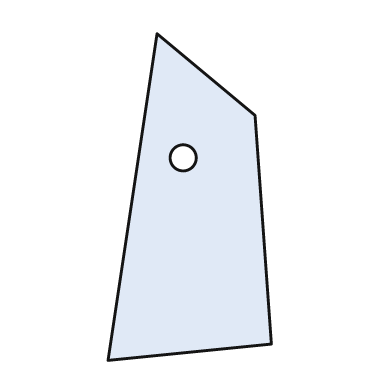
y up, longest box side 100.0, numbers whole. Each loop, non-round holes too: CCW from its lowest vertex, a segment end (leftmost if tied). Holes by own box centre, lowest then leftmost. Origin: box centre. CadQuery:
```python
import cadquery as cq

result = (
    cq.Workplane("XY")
    .moveTo(-25.0, -50.0)
    .lineTo(25.0, -45.0)
    .lineTo(20.0, 25.0)
    .lineTo(-10.0, 50.0)
    .close()
    .moveTo(-2.0, 12.0)
    .circle(4.0)
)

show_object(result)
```